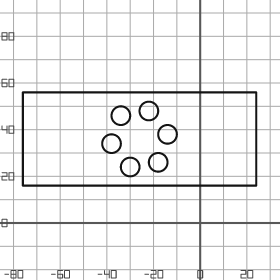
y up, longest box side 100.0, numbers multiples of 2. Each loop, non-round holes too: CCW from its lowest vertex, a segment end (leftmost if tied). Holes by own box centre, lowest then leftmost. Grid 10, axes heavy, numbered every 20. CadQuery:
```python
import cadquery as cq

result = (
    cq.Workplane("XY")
    .moveTo(-76.0, 16.0)
    .lineTo(24.0, 16.0)
    .lineTo(24.0, 56.0)
    .lineTo(-76.0, 56.0)
    .close()
    .moveTo(-30.0, 24.0)
    .circle(4.0)
    .moveTo(-18.0, 26.0)
    .circle(4.0)
    .moveTo(-38.0, 34.0)
    .circle(4.0)
    .moveTo(-14.0, 38.0)
    .circle(4.0)
    .moveTo(-34.0, 46.0)
    .circle(4.0)
    .moveTo(-22.0, 48.0)
    .circle(4.0)
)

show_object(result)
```